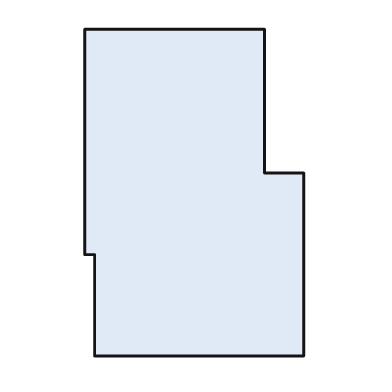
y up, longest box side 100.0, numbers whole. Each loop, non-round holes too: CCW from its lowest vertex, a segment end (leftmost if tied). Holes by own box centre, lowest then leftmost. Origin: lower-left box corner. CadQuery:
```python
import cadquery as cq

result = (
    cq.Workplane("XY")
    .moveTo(3.0, 0.0)
    .lineTo(67.0, 0.0)
    .lineTo(67.0, 56.0)
    .lineTo(55.0, 56.0)
    .lineTo(55.0, 100.0)
    .lineTo(0.0, 100.0)
    .lineTo(0.0, 31.0)
    .lineTo(3.0, 31.0)
    .close()
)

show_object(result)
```